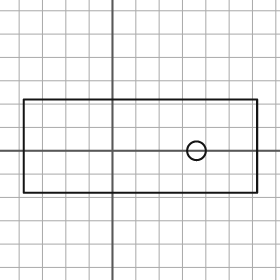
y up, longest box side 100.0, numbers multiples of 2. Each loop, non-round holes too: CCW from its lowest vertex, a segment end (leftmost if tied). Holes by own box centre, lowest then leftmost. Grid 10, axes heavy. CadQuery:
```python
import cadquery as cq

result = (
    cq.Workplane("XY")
    .moveTo(-38.0, -18.0)
    .lineTo(62.0, -18.0)
    .lineTo(62.0, 22.0)
    .lineTo(-38.0, 22.0)
    .close()
    .moveTo(36.0, 0.0)
    .circle(4.0)
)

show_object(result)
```